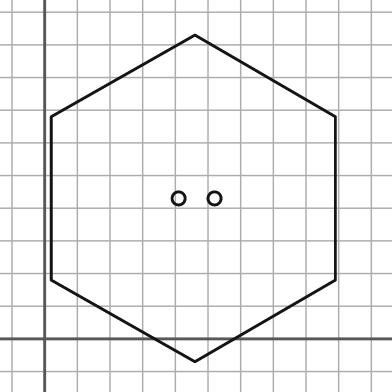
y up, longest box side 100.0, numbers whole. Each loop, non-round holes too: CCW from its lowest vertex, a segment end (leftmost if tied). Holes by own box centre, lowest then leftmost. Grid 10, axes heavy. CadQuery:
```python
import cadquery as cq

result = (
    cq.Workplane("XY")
    .moveTo(46.0, -7.0)
    .lineTo(89.0, 18.0)
    .lineTo(89.0, 68.0)
    .lineTo(46.0, 93.0)
    .lineTo(2.0, 68.0)
    .lineTo(2.0, 18.0)
    .close()
    .moveTo(41.0, 43.0)
    .circle(2.0)
    .moveTo(52.0, 43.0)
    .circle(2.0)
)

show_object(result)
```